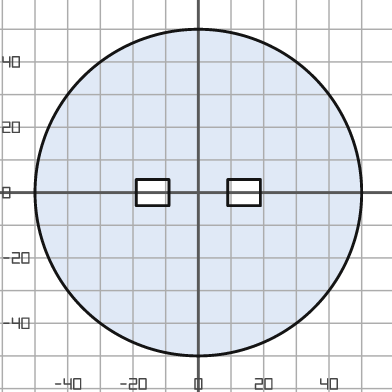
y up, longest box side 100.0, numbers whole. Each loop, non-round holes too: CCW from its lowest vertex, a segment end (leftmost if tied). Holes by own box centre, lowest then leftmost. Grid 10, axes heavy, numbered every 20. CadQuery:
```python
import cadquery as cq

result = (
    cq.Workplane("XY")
    .moveTo(0.0, 0.0)
    .circle(50.0)
    .moveTo(-19.0, -4.0)
    .lineTo(-9.0, -4.0)
    .lineTo(-9.0, 4.0)
    .lineTo(-19.0, 4.0)
    .close()
    .moveTo(9.0, -4.0)
    .lineTo(19.0, -4.0)
    .lineTo(19.0, 4.0)
    .lineTo(9.0, 4.0)
    .close()
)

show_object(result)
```